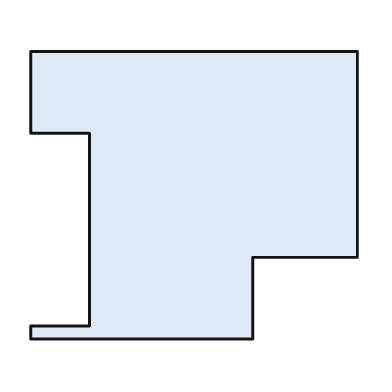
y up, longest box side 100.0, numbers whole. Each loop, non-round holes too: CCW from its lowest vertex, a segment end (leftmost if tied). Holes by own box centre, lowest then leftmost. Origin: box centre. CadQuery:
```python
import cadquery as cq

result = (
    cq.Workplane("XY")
    .moveTo(-50.0, -44.0)
    .lineTo(18.0, -44.0)
    .lineTo(18.0, -19.0)
    .lineTo(50.0, -19.0)
    .lineTo(50.0, 44.0)
    .lineTo(-50.0, 44.0)
    .lineTo(-50.0, 19.0)
    .lineTo(-32.0, 19.0)
    .lineTo(-32.0, -40.0)
    .lineTo(-50.0, -40.0)
    .close()
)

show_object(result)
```